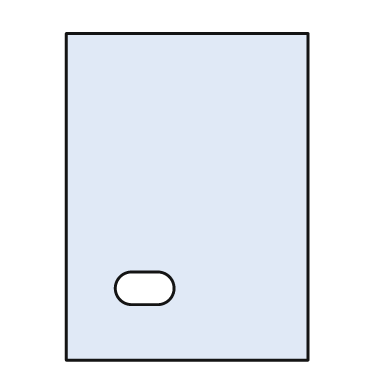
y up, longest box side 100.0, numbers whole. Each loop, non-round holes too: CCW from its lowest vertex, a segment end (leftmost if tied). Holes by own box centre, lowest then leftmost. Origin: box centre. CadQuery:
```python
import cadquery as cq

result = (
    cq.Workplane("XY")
    .moveTo(-37.0, -50.0)
    .lineTo(37.0, -50.0)
    .lineTo(37.0, 50.0)
    .lineTo(-37.0, 50.0)
    .close()
    .moveTo(-17.0, -33.0)
    .lineTo(-9.0, -33.0)
    .threePointArc((-4.0, -28.0), (-9.0, -23.0))
    .lineTo(-17.0, -23.0)
    .threePointArc((-22.0, -28.0), (-17.0, -33.0))
    .close()
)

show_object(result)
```